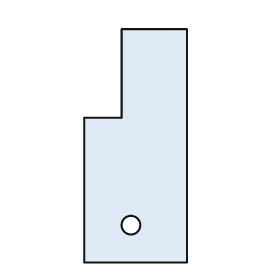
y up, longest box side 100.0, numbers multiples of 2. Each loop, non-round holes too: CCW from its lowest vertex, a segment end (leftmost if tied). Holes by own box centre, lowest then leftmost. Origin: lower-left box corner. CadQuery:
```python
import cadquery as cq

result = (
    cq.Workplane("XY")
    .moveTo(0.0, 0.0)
    .lineTo(44.0, 0.0)
    .lineTo(44.0, 100.0)
    .lineTo(16.0, 100.0)
    .lineTo(16.0, 62.0)
    .lineTo(0.0, 62.0)
    .close()
    .moveTo(20.0, 16.0)
    .circle(4.0)
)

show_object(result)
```